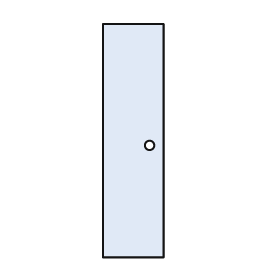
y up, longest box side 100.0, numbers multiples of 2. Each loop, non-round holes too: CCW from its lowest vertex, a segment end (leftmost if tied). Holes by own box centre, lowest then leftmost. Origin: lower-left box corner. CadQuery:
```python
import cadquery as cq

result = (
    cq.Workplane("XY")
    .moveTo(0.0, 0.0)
    .lineTo(26.0, 0.0)
    .lineTo(26.0, 100.0)
    .lineTo(0.0, 100.0)
    .close()
    .moveTo(20.0, 48.0)
    .circle(2.0)
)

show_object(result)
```